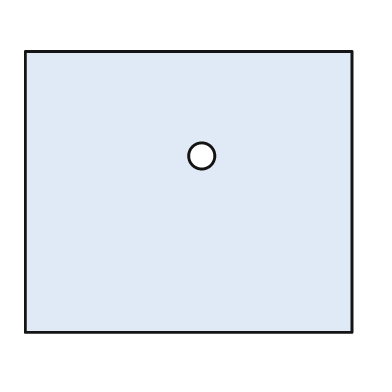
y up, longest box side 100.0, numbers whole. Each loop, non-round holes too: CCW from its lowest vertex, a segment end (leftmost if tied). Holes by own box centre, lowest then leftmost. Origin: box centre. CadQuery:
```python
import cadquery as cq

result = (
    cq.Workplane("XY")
    .moveTo(-50.0, -43.0)
    .lineTo(50.0, -43.0)
    .lineTo(50.0, 43.0)
    .lineTo(-50.0, 43.0)
    .close()
    .moveTo(4.0, 11.0)
    .circle(4.0)
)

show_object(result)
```